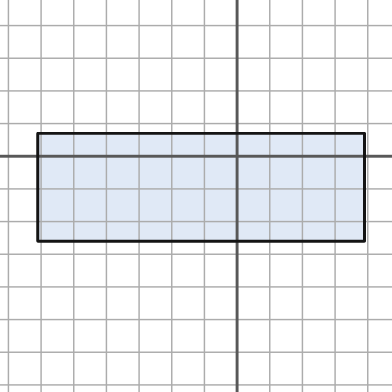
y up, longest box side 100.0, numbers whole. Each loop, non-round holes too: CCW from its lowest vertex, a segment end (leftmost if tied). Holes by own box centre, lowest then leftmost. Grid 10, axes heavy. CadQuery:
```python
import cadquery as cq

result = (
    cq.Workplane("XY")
    .moveTo(-61.0, -26.0)
    .lineTo(39.0, -26.0)
    .lineTo(39.0, 7.0)
    .lineTo(-61.0, 7.0)
    .close()
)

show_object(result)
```